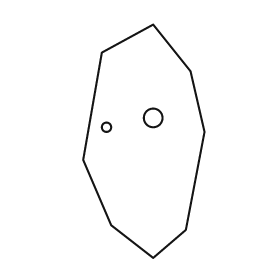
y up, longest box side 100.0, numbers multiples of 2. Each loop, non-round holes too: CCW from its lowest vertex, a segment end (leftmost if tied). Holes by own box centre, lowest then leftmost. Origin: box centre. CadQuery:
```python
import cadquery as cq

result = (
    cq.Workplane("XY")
    .moveTo(4.0, -50.0)
    .lineTo(18.0, -38.0)
    .lineTo(26.0, 4.0)
    .lineTo(20.0, 30.0)
    .lineTo(4.0, 50.0)
    .lineTo(-18.0, 38.0)
    .lineTo(-26.0, -8.0)
    .lineTo(-14.0, -36.0)
    .close()
    .moveTo(-16.0, 6.0)
    .circle(2.0)
    .moveTo(4.0, 10.0)
    .circle(4.0)
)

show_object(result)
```